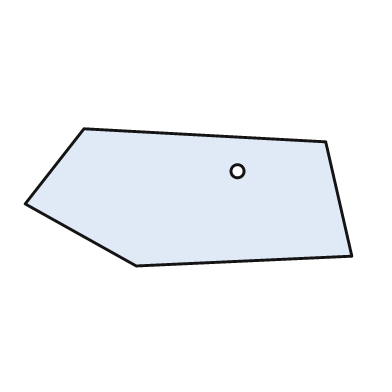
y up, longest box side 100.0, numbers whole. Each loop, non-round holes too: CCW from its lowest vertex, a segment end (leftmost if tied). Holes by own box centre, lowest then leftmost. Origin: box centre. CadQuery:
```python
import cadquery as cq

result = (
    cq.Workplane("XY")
    .moveTo(-16.0, -21.0)
    .lineTo(50.0, -18.0)
    .lineTo(42.0, 17.0)
    .lineTo(-32.0, 21.0)
    .lineTo(-50.0, -2.0)
    .close()
    .moveTo(15.0, 8.0)
    .circle(2.0)
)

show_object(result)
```